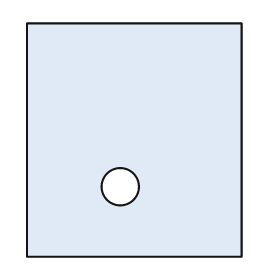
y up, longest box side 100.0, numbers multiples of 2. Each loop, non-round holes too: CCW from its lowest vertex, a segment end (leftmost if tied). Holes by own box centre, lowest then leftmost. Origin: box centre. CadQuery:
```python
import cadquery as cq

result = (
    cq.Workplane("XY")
    .moveTo(-46.0, -50.0)
    .lineTo(46.0, -50.0)
    .lineTo(46.0, 50.0)
    .lineTo(-46.0, 50.0)
    .close()
    .moveTo(-6.0, -20.0)
    .circle(8.0)
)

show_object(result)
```